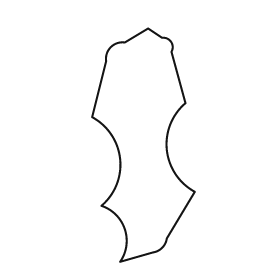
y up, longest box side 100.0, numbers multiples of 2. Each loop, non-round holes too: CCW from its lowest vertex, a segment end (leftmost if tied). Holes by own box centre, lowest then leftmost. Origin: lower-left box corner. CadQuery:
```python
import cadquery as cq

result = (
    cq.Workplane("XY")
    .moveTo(12.0, 0.0)
    .lineTo(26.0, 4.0)
    .threePointArc((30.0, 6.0), (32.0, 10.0))
    .lineTo(44.0, 30.0)
    .threePointArc((32.0, 48.0), (40.0, 68.0))
    .lineTo(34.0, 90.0)
    .threePointArc((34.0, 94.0), (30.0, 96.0))
    .lineTo(24.0, 100.0)
    .lineTo(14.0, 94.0)
    .threePointArc((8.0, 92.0), (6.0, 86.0))
    .lineTo(0.0, 62.0)
    .threePointArc((12.0, 44.0), (4.0, 24.0))
    .threePointArc((14.0, 14.0), (12.0, 0.0))
    .close()
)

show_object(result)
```